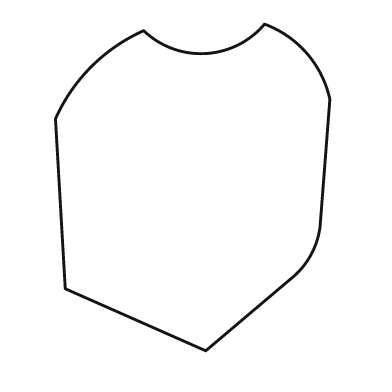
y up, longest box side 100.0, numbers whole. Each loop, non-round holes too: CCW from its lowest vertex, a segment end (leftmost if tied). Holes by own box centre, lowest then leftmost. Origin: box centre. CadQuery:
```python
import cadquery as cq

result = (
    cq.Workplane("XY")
    .moveTo(4.0, -50.0)
    .lineTo(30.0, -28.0)
    .threePointArc((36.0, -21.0), (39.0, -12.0))
    .lineTo(42.0, 27.0)
    .threePointArc((35.0, 41.0), (22.0, 50.0))
    .threePointArc((4.0, 41.0), (-15.0, 48.0))
    .threePointArc((-31.0, 37.0), (-42.0, 21.0))
    .lineTo(-39.0, -31.0)
    .close()
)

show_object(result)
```